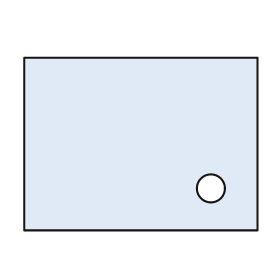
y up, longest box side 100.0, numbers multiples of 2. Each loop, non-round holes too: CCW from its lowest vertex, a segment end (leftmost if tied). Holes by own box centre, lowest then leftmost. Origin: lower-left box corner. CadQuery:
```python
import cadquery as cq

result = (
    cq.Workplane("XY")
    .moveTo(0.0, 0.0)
    .lineTo(100.0, 0.0)
    .lineTo(100.0, 74.0)
    .lineTo(0.0, 74.0)
    .close()
    .moveTo(80.0, 18.0)
    .circle(6.0)
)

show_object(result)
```